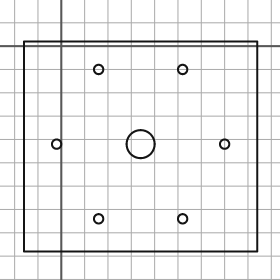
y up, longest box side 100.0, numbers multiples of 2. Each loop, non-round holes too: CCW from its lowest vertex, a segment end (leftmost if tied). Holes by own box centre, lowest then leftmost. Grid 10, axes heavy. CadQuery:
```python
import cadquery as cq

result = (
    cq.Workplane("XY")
    .moveTo(-16.0, -88.0)
    .lineTo(84.0, -88.0)
    .lineTo(84.0, 2.0)
    .lineTo(-16.0, 2.0)
    .close()
    .moveTo(16.0, -74.0)
    .circle(2.0)
    .moveTo(52.0, -74.0)
    .circle(2.0)
    .moveTo(-2.0, -42.0)
    .circle(2.0)
    .moveTo(34.0, -42.0)
    .circle(6.0)
    .moveTo(70.0, -42.0)
    .circle(2.0)
    .moveTo(16.0, -10.0)
    .circle(2.0)
    .moveTo(52.0, -10.0)
    .circle(2.0)
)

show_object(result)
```